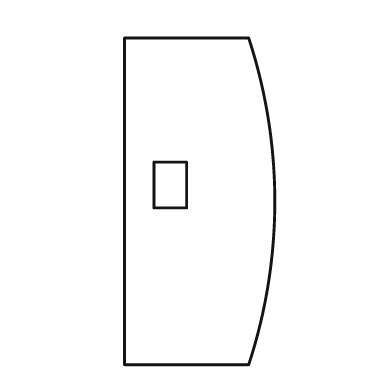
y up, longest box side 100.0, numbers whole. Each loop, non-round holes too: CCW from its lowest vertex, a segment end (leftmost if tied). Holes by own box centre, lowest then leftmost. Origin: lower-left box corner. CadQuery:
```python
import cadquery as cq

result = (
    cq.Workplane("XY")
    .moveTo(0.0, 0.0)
    .lineTo(38.0, 0.0)
    .threePointArc((46.0, 50.0), (38.0, 100.0))
    .lineTo(0.0, 100.0)
    .close()
    .moveTo(9.0, 48.0)
    .lineTo(19.0, 48.0)
    .lineTo(19.0, 62.0)
    .lineTo(9.0, 62.0)
    .close()
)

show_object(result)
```